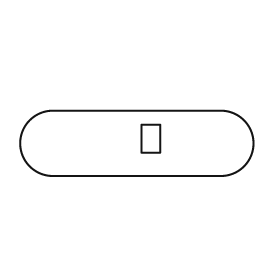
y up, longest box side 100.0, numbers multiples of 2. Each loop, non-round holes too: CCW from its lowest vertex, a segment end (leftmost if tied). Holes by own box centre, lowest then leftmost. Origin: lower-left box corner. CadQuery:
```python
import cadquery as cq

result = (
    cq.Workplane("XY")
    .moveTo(14.0, 0.0)
    .lineTo(86.0, 0.0)
    .threePointArc((100.0, 14.0), (86.0, 28.0))
    .lineTo(14.0, 28.0)
    .threePointArc((0.0, 14.0), (14.0, 0.0))
    .close()
    .moveTo(52.0, 10.0)
    .lineTo(60.0, 10.0)
    .lineTo(60.0, 22.0)
    .lineTo(52.0, 22.0)
    .close()
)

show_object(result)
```